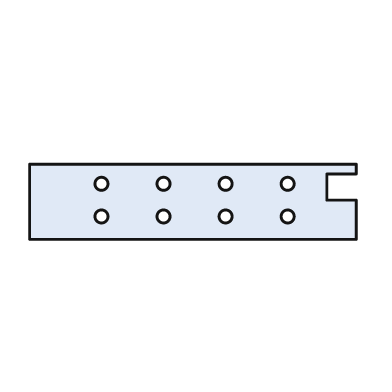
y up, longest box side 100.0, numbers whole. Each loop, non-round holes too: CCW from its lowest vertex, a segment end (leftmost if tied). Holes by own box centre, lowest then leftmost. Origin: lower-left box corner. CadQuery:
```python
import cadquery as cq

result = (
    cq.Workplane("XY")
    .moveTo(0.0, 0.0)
    .lineTo(100.0, 0.0)
    .lineTo(100.0, 12.0)
    .lineTo(91.0, 12.0)
    .lineTo(91.0, 20.0)
    .lineTo(100.0, 20.0)
    .lineTo(100.0, 23.0)
    .lineTo(0.0, 23.0)
    .close()
    .moveTo(22.0, 7.0)
    .circle(2.0)
    .moveTo(41.0, 7.0)
    .circle(2.0)
    .moveTo(60.0, 7.0)
    .circle(2.0)
    .moveTo(79.0, 7.0)
    .circle(2.0)
    .moveTo(22.0, 17.0)
    .circle(2.0)
    .moveTo(41.0, 17.0)
    .circle(2.0)
    .moveTo(60.0, 17.0)
    .circle(2.0)
    .moveTo(79.0, 17.0)
    .circle(2.0)
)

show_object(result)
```